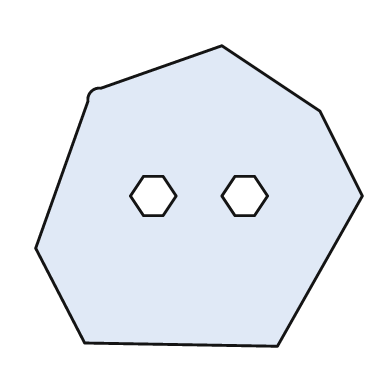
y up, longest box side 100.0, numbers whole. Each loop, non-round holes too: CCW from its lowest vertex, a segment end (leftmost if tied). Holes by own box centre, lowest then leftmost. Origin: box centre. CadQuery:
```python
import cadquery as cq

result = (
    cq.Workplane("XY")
    .moveTo(24.0, -46.0)
    .lineTo(50.0, 0.0)
    .lineTo(37.0, 26.0)
    .lineTo(7.0, 46.0)
    .lineTo(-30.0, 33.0)
    .threePointArc((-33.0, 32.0), (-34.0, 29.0))
    .lineTo(-50.0, -16.0)
    .lineTo(-35.0, -45.0)
    .close()
    .moveTo(-17.0, -6.0)
    .lineTo(-11.0, -6.0)
    .lineTo(-7.0, 0.0)
    .lineTo(-11.0, 6.0)
    .lineTo(-17.0, 6.0)
    .lineTo(-21.0, 0.0)
    .close()
    .moveTo(11.0, -6.0)
    .lineTo(17.0, -6.0)
    .lineTo(21.0, 0.0)
    .lineTo(17.0, 6.0)
    .lineTo(11.0, 6.0)
    .lineTo(7.0, 0.0)
    .close()
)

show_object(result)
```